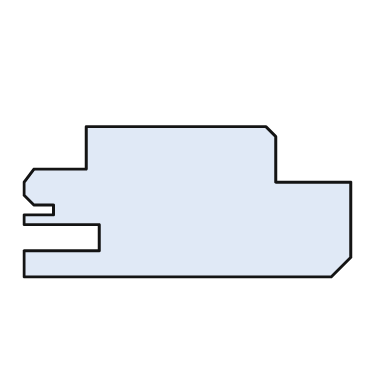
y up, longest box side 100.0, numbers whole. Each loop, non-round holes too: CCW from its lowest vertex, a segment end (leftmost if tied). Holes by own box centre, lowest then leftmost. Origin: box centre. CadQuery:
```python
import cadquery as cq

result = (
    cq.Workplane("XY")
    .moveTo(-50.0, -23.0)
    .lineTo(44.0, -23.0)
    .lineTo(50.0, -17.0)
    .lineTo(50.0, 6.0)
    .lineTo(27.0, 6.0)
    .lineTo(27.0, 20.0)
    .lineTo(24.0, 23.0)
    .lineTo(-31.0, 23.0)
    .lineTo(-31.0, 10.0)
    .lineTo(-47.0, 10.0)
    .lineTo(-50.0, 6.0)
    .lineTo(-50.0, 2.0)
    .lineTo(-47.0, -1.0)
    .lineTo(-41.0, -1.0)
    .lineTo(-41.0, -4.0)
    .lineTo(-50.0, -4.0)
    .lineTo(-50.0, -7.0)
    .lineTo(-27.0, -7.0)
    .lineTo(-27.0, -15.0)
    .lineTo(-50.0, -15.0)
    .close()
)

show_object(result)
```